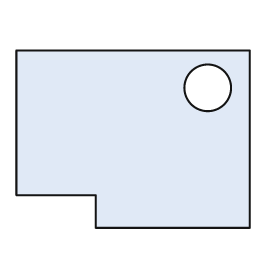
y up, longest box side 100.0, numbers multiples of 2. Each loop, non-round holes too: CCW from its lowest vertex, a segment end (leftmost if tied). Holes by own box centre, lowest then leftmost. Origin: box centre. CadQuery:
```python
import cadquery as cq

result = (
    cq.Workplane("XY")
    .moveTo(-16.0, -38.0)
    .lineTo(50.0, -38.0)
    .lineTo(50.0, 38.0)
    .lineTo(-50.0, 38.0)
    .lineTo(-50.0, -24.0)
    .lineTo(-16.0, -24.0)
    .close()
    .moveTo(32.0, 22.0)
    .circle(10.0)
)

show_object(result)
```